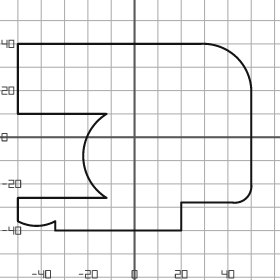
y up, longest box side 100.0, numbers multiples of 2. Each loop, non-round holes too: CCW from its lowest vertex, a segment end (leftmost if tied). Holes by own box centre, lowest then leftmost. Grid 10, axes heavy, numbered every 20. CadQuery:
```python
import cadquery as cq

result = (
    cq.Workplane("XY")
    .moveTo(-34.0, -40.0)
    .lineTo(20.0, -40.0)
    .lineTo(20.0, -28.0)
    .lineTo(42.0, -28.0)
    .threePointArc((48.0, -26.0), (50.0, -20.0))
    .lineTo(50.0, 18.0)
    .threePointArc((44.0, 34.0), (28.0, 40.0))
    .lineTo(-50.0, 40.0)
    .lineTo(-50.0, 10.0)
    .lineTo(-12.0, 10.0)
    .threePointArc((-22.0, -8.0), (-12.0, -26.0))
    .lineTo(-50.0, -26.0)
    .lineTo(-50.0, -36.0)
    .threePointArc((-42.0, -38.0), (-34.0, -36.0))
    .close()
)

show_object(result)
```